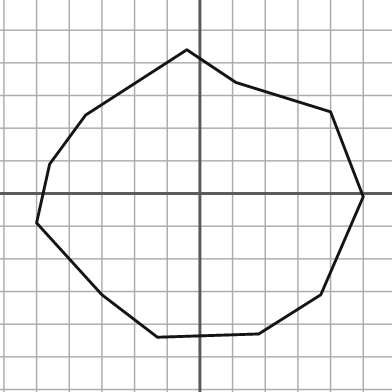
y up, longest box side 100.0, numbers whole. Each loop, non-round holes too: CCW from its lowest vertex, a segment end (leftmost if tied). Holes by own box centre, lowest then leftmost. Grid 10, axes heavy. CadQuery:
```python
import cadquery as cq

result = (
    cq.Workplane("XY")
    .moveTo(-13.0, -44.0)
    .lineTo(18.0, -43.0)
    .lineTo(37.0, -31.0)
    .lineTo(50.0, -1.0)
    .lineTo(40.0, 25.0)
    .lineTo(11.0, 34.0)
    .lineTo(-4.0, 44.0)
    .lineTo(-35.0, 24.0)
    .lineTo(-46.0, 9.0)
    .lineTo(-50.0, -9.0)
    .lineTo(-30.0, -31.0)
    .close()
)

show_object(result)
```